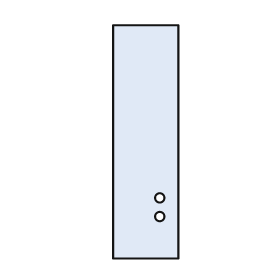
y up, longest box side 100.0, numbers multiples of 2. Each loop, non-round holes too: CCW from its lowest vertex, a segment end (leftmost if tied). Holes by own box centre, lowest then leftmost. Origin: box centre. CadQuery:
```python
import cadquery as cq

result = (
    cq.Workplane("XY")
    .moveTo(-14.0, -50.0)
    .lineTo(14.0, -50.0)
    .lineTo(14.0, 50.0)
    .lineTo(-14.0, 50.0)
    .close()
    .moveTo(6.0, -32.0)
    .circle(2.0)
    .moveTo(6.0, -24.0)
    .circle(2.0)
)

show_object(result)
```